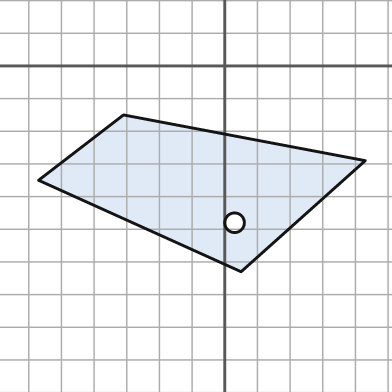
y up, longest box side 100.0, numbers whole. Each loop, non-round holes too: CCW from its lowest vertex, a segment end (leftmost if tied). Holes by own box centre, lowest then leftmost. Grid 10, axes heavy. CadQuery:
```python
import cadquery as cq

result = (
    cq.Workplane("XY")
    .moveTo(5.0, -63.0)
    .lineTo(43.0, -29.0)
    .lineTo(-31.0, -15.0)
    .lineTo(-57.0, -35.0)
    .close()
    .moveTo(3.0, -48.0)
    .circle(3.0)
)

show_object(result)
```